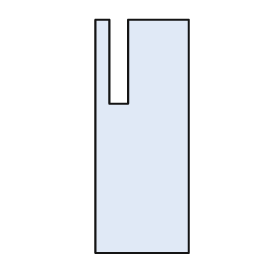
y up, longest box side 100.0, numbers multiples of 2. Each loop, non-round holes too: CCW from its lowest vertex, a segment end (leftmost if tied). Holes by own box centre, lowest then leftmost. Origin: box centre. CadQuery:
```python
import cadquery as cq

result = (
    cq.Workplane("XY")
    .moveTo(-20.0, -50.0)
    .lineTo(20.0, -50.0)
    .lineTo(20.0, 50.0)
    .lineTo(-6.0, 50.0)
    .lineTo(-6.0, 14.0)
    .lineTo(-14.0, 14.0)
    .lineTo(-14.0, 50.0)
    .lineTo(-20.0, 50.0)
    .close()
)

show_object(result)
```